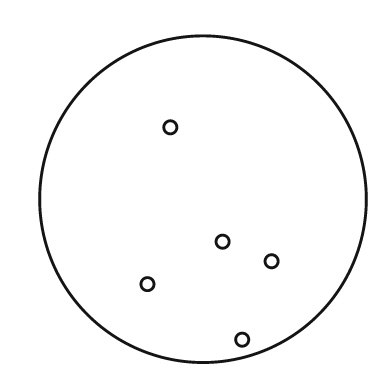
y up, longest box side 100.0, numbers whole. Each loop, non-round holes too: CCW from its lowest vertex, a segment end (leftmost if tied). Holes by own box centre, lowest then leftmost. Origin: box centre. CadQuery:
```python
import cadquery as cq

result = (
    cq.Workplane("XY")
    .moveTo(0.0, 0.0)
    .circle(50.0)
    .moveTo(12.0, -43.0)
    .circle(2.0)
    .moveTo(-17.0, -26.0)
    .circle(2.0)
    .moveTo(21.0, -19.0)
    .circle(2.0)
    .moveTo(6.0, -13.0)
    .circle(2.0)
    .moveTo(-10.0, 22.0)
    .circle(2.0)
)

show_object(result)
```